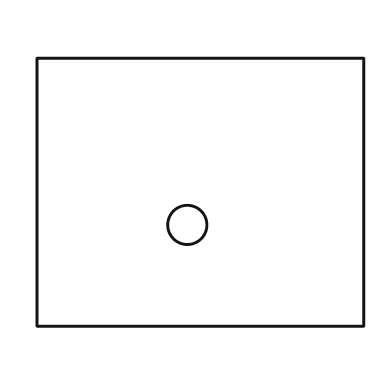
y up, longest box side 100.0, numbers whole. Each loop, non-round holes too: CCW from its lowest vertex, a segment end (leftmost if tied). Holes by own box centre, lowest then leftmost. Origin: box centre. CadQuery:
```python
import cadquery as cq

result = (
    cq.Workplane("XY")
    .moveTo(-50.0, -41.0)
    .lineTo(50.0, -41.0)
    .lineTo(50.0, 41.0)
    .lineTo(-50.0, 41.0)
    .close()
    .moveTo(-4.0, -10.0)
    .circle(6.0)
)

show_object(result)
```